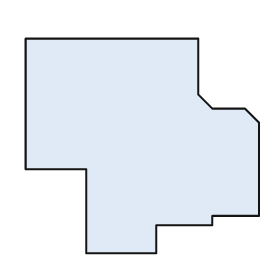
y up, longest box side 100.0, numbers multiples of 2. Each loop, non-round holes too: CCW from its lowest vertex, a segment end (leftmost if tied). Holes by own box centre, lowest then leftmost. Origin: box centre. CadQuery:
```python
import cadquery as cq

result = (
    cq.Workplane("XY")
    .moveTo(-24.0, -46.0)
    .lineTo(6.0, -46.0)
    .lineTo(6.0, -34.0)
    .lineTo(30.0, -34.0)
    .lineTo(30.0, -30.0)
    .lineTo(50.0, -30.0)
    .lineTo(50.0, 10.0)
    .lineTo(44.0, 16.0)
    .lineTo(30.0, 16.0)
    .lineTo(24.0, 22.0)
    .lineTo(24.0, 46.0)
    .lineTo(-50.0, 46.0)
    .lineTo(-50.0, -10.0)
    .lineTo(-24.0, -10.0)
    .close()
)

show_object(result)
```